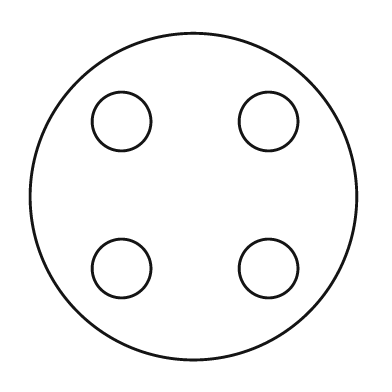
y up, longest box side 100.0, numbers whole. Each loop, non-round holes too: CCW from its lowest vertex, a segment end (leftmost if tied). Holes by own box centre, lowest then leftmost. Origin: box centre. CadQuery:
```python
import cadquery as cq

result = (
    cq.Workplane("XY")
    .moveTo(0.0, 0.0)
    .circle(50.0)
    .moveTo(-22.0, -22.0)
    .circle(9.0)
    .moveTo(23.0, -22.0)
    .circle(9.0)
    .moveTo(-22.0, 23.0)
    .circle(9.0)
    .moveTo(23.0, 23.0)
    .circle(9.0)
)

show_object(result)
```